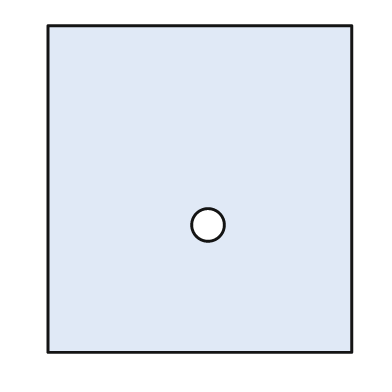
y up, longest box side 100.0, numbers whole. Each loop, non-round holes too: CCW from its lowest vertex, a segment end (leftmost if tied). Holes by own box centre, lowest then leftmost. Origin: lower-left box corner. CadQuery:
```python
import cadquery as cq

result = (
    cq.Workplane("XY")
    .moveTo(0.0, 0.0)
    .lineTo(93.0, 0.0)
    .lineTo(93.0, 100.0)
    .lineTo(0.0, 100.0)
    .close()
    .moveTo(49.0, 39.0)
    .circle(5.0)
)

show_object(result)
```